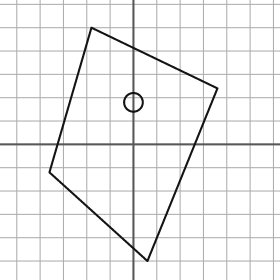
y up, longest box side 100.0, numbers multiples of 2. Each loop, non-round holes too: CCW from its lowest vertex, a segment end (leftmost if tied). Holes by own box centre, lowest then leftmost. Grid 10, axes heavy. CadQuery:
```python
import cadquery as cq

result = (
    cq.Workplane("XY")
    .moveTo(6.0, -50.0)
    .lineTo(36.0, 24.0)
    .lineTo(-18.0, 50.0)
    .lineTo(-36.0, -12.0)
    .close()
    .moveTo(0.0, 18.0)
    .circle(4.0)
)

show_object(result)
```